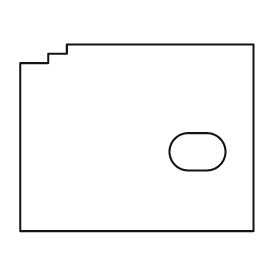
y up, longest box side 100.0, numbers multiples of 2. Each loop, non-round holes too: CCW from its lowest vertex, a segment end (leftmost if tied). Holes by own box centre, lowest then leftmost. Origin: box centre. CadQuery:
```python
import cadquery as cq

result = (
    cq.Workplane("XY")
    .moveTo(-50.0, -40.0)
    .lineTo(50.0, -40.0)
    .lineTo(50.0, 40.0)
    .lineTo(-30.0, 40.0)
    .lineTo(-30.0, 36.0)
    .lineTo(-38.0, 36.0)
    .lineTo(-38.0, 32.0)
    .lineTo(-50.0, 32.0)
    .close()
    .moveTo(22.0, -14.0)
    .lineTo(30.0, -14.0)
    .threePointArc((38.0, -6.0), (30.0, 2.0))
    .lineTo(22.0, 2.0)
    .threePointArc((14.0, -6.0), (22.0, -14.0))
    .close()
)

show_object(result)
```